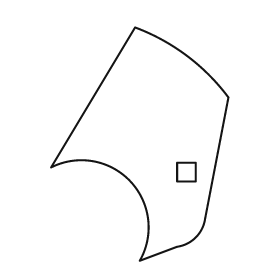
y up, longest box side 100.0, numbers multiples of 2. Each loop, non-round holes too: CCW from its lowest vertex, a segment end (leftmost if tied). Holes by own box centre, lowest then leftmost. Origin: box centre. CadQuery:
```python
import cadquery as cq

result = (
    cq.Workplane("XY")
    .moveTo(0.0, -50.0)
    .lineTo(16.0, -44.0)
    .threePointArc((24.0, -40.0), (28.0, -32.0))
    .lineTo(38.0, 20.0)
    .threePointArc((20.0, 38.0), (-2.0, 50.0))
    .lineTo(-38.0, -10.0)
    .threePointArc((-4.0, -16.0), (0.0, -50.0))
    .close()
    .moveTo(16.0, -16.0)
    .lineTo(24.0, -16.0)
    .lineTo(24.0, -8.0)
    .lineTo(16.0, -8.0)
    .close()
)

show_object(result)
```